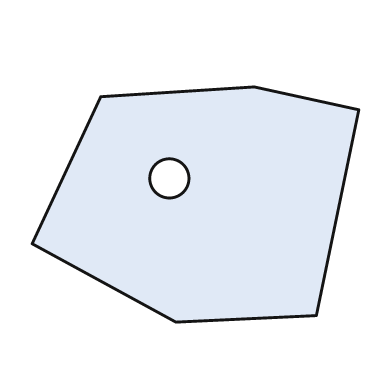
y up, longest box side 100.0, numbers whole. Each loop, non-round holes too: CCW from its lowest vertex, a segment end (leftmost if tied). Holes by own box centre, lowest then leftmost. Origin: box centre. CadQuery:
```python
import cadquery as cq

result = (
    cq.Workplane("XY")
    .moveTo(-6.0, -36.0)
    .lineTo(37.0, -34.0)
    .lineTo(50.0, 29.0)
    .lineTo(18.0, 36.0)
    .lineTo(-29.0, 33.0)
    .lineTo(-50.0, -12.0)
    .close()
    .moveTo(-8.0, 8.0)
    .circle(6.0)
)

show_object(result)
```